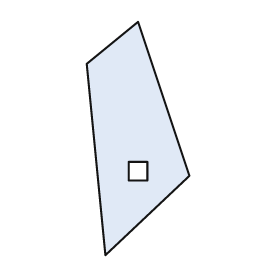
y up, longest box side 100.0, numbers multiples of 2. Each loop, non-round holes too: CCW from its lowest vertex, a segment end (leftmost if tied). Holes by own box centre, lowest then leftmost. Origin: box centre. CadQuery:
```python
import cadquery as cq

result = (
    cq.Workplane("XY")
    .moveTo(-14.0, -50.0)
    .lineTo(22.0, -16.0)
    .lineTo(0.0, 50.0)
    .lineTo(-22.0, 32.0)
    .close()
    .moveTo(-4.0, -18.0)
    .lineTo(4.0, -18.0)
    .lineTo(4.0, -10.0)
    .lineTo(-4.0, -10.0)
    .close()
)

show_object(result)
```